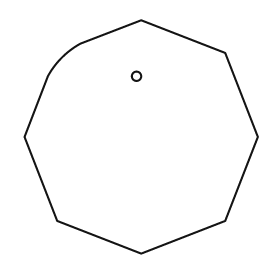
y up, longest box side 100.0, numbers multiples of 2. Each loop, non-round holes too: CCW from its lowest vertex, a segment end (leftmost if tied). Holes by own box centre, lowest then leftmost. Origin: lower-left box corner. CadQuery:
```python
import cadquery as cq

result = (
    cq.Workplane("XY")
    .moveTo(50.0, 0.0)
    .lineTo(86.0, 14.0)
    .lineTo(100.0, 50.0)
    .lineTo(86.0, 86.0)
    .lineTo(50.0, 100.0)
    .lineTo(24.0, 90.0)
    .threePointArc((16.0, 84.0), (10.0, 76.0))
    .lineTo(0.0, 50.0)
    .lineTo(14.0, 14.0)
    .close()
    .moveTo(48.0, 76.0)
    .circle(2.0)
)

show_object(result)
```